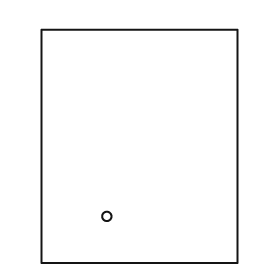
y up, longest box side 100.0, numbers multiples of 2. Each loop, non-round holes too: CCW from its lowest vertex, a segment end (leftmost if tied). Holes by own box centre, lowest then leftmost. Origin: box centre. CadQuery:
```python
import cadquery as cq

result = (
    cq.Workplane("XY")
    .moveTo(-42.0, -50.0)
    .lineTo(42.0, -50.0)
    .lineTo(42.0, 50.0)
    .lineTo(-42.0, 50.0)
    .close()
    .moveTo(-14.0, -30.0)
    .circle(2.0)
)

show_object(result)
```